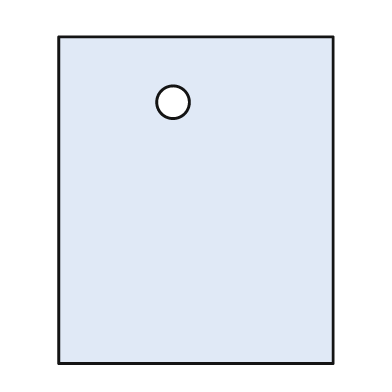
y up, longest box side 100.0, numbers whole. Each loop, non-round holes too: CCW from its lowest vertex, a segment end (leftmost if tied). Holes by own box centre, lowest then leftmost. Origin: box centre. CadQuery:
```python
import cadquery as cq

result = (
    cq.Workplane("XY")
    .moveTo(-42.0, -50.0)
    .lineTo(42.0, -50.0)
    .lineTo(42.0, 50.0)
    .lineTo(-42.0, 50.0)
    .close()
    .moveTo(-7.0, 30.0)
    .circle(5.0)
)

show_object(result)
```